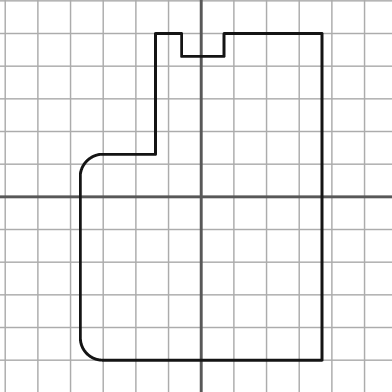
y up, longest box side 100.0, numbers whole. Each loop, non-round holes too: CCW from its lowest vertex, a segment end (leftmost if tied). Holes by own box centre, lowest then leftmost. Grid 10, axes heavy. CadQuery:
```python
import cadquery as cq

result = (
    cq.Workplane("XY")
    .moveTo(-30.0, -50.0)
    .lineTo(37.0, -50.0)
    .lineTo(37.0, 50.0)
    .lineTo(7.0, 50.0)
    .lineTo(7.0, 43.0)
    .lineTo(-6.0, 43.0)
    .lineTo(-6.0, 50.0)
    .lineTo(-14.0, 50.0)
    .lineTo(-14.0, 13.0)
    .lineTo(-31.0, 13.0)
    .threePointArc((-35.0, 11.0), (-37.0, 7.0))
    .lineTo(-37.0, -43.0)
    .threePointArc((-35.0, -48.0), (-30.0, -50.0))
    .close()
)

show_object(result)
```